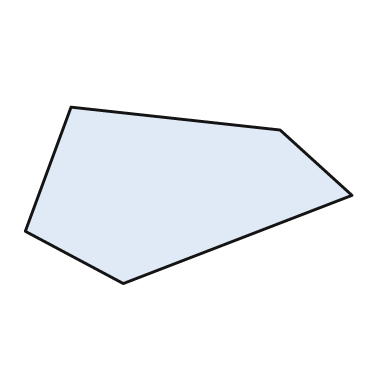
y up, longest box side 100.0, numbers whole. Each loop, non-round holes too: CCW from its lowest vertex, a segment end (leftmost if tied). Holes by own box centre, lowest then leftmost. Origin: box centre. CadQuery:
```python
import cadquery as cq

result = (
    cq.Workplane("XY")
    .moveTo(-20.0, -27.0)
    .lineTo(50.0, 0.0)
    .lineTo(28.0, 20.0)
    .lineTo(-36.0, 27.0)
    .lineTo(-50.0, -11.0)
    .close()
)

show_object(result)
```